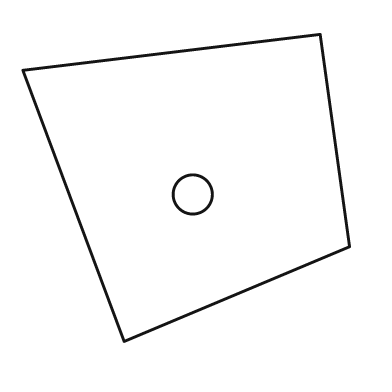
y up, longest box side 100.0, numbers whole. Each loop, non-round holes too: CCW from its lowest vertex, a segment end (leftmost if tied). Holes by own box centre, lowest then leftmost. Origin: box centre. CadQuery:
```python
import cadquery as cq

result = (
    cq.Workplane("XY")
    .moveTo(-19.0, -47.0)
    .lineTo(50.0, -18.0)
    .lineTo(41.0, 47.0)
    .lineTo(-50.0, 36.0)
    .close()
    .moveTo(2.0, -2.0)
    .circle(6.0)
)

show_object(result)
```